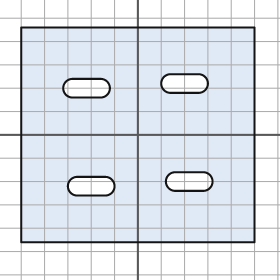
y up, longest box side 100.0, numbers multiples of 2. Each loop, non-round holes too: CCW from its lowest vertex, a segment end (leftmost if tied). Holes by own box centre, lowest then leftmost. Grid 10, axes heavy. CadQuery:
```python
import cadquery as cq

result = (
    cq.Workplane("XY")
    .moveTo(-50.0, -46.0)
    .lineTo(50.0, -46.0)
    .lineTo(50.0, 46.0)
    .lineTo(-50.0, 46.0)
    .close()
    .moveTo(-26.0, -26.0)
    .lineTo(-14.0, -26.0)
    .threePointArc((-10.0, -22.0), (-14.0, -18.0))
    .lineTo(-26.0, -18.0)
    .threePointArc((-30.0, -22.0), (-26.0, -26.0))
    .close()
    .moveTo(16.0, -24.0)
    .lineTo(28.0, -24.0)
    .threePointArc((32.0, -20.0), (28.0, -16.0))
    .lineTo(16.0, -16.0)
    .threePointArc((12.0, -20.0), (16.0, -24.0))
    .close()
    .moveTo(-28.0, 16.0)
    .lineTo(-16.0, 16.0)
    .threePointArc((-12.0, 20.0), (-16.0, 24.0))
    .lineTo(-28.0, 24.0)
    .threePointArc((-32.0, 20.0), (-28.0, 16.0))
    .close()
    .moveTo(14.0, 18.0)
    .lineTo(26.0, 18.0)
    .threePointArc((30.0, 22.0), (26.0, 26.0))
    .lineTo(14.0, 26.0)
    .threePointArc((10.0, 22.0), (14.0, 18.0))
    .close()
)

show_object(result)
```